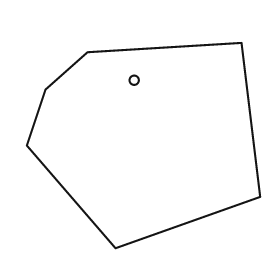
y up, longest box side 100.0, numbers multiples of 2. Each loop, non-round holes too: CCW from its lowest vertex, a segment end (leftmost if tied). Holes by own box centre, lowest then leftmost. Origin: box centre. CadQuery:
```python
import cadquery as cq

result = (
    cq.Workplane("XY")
    .moveTo(-12.0, -44.0)
    .lineTo(50.0, -22.0)
    .lineTo(42.0, 44.0)
    .lineTo(-24.0, 40.0)
    .lineTo(-42.0, 24.0)
    .lineTo(-50.0, 0.0)
    .close()
    .moveTo(-4.0, 28.0)
    .circle(2.0)
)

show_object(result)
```